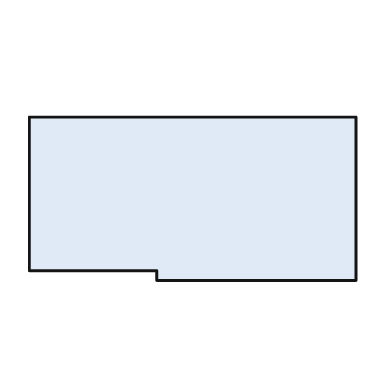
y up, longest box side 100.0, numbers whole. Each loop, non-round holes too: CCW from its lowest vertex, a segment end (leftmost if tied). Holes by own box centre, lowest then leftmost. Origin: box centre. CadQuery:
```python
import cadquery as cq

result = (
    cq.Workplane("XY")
    .moveTo(-11.0, -25.0)
    .lineTo(50.0, -25.0)
    .lineTo(50.0, 25.0)
    .lineTo(-50.0, 25.0)
    .lineTo(-50.0, -22.0)
    .lineTo(-11.0, -22.0)
    .close()
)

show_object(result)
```